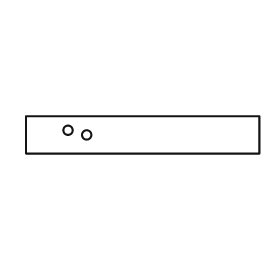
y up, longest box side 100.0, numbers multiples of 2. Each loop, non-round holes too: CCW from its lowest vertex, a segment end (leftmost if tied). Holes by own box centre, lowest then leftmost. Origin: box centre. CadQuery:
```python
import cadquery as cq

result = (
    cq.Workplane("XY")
    .moveTo(-50.0, -8.0)
    .lineTo(50.0, -8.0)
    .lineTo(50.0, 8.0)
    .lineTo(-50.0, 8.0)
    .close()
    .moveTo(-24.0, 0.0)
    .circle(2.0)
    .moveTo(-32.0, 2.0)
    .circle(2.0)
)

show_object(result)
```